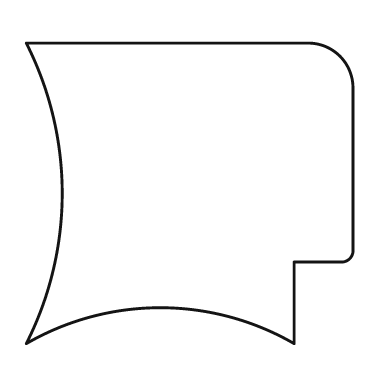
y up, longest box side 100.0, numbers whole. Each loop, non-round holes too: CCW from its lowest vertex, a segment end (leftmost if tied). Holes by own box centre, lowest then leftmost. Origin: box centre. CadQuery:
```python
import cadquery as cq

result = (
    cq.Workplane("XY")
    .moveTo(-50.0, -46.0)
    .threePointArc((-9.0, -35.0), (32.0, -46.0))
    .lineTo(32.0, -21.0)
    .lineTo(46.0, -21.0)
    .threePointArc((49.0, -20.0), (50.0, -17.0))
    .lineTo(50.0, 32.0)
    .threePointArc((46.0, 42.0), (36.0, 46.0))
    .lineTo(-50.0, 46.0)
    .threePointArc((-39.0, 0.0), (-50.0, -46.0))
    .close()
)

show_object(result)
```